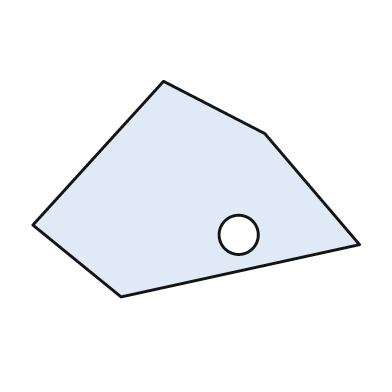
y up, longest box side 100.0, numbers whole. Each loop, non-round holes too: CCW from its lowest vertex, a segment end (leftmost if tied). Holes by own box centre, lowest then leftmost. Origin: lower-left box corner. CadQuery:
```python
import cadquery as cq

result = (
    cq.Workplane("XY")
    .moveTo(27.0, 0.0)
    .lineTo(100.0, 16.0)
    .lineTo(71.0, 50.0)
    .lineTo(40.0, 66.0)
    .lineTo(0.0, 22.0)
    .close()
    .moveTo(63.0, 19.0)
    .circle(6.0)
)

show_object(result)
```